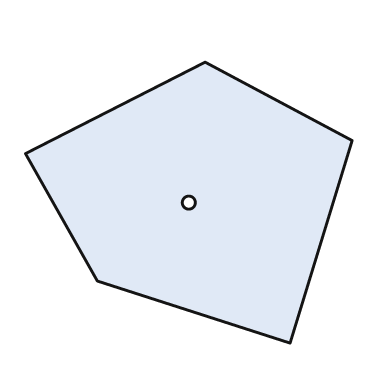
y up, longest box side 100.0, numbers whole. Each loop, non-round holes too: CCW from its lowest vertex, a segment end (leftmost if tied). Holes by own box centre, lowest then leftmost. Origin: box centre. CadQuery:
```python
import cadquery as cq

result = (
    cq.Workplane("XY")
    .moveTo(31.0, -43.0)
    .lineTo(50.0, 19.0)
    .lineTo(5.0, 43.0)
    .lineTo(-50.0, 15.0)
    .lineTo(-28.0, -24.0)
    .close()
    .moveTo(0.0, 0.0)
    .circle(2.0)
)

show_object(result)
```